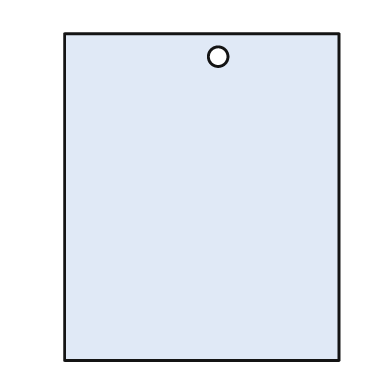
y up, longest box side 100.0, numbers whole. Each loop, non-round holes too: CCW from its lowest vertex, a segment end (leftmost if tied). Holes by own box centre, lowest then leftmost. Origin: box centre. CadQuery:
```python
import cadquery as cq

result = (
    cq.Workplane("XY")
    .moveTo(-42.0, -50.0)
    .lineTo(42.0, -50.0)
    .lineTo(42.0, 50.0)
    .lineTo(-42.0, 50.0)
    .close()
    .moveTo(5.0, 43.0)
    .circle(3.0)
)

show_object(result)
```